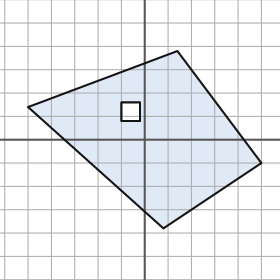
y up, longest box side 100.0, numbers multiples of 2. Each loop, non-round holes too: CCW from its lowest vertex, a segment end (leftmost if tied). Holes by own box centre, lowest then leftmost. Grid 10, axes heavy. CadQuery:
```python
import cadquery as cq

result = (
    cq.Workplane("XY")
    .moveTo(8.0, -38.0)
    .lineTo(50.0, -10.0)
    .lineTo(14.0, 38.0)
    .lineTo(-50.0, 14.0)
    .close()
    .moveTo(-10.0, 8.0)
    .lineTo(-2.0, 8.0)
    .lineTo(-2.0, 16.0)
    .lineTo(-10.0, 16.0)
    .close()
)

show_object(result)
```